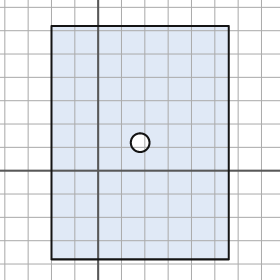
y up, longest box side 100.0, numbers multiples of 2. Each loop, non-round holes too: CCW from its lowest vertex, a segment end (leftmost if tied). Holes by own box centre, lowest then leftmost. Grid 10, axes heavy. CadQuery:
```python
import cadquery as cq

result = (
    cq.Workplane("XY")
    .moveTo(-20.0, -38.0)
    .lineTo(56.0, -38.0)
    .lineTo(56.0, 62.0)
    .lineTo(-20.0, 62.0)
    .close()
    .moveTo(18.0, 12.0)
    .circle(4.0)
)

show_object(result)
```